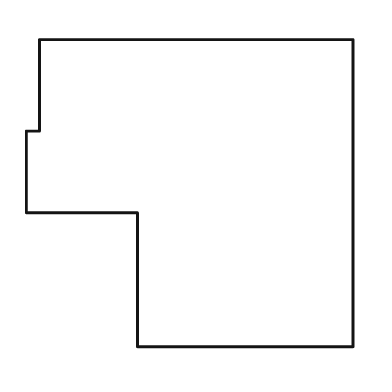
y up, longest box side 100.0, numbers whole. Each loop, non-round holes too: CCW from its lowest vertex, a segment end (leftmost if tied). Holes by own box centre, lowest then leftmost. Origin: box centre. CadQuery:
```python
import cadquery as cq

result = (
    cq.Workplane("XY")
    .moveTo(-16.0, -47.0)
    .lineTo(50.0, -47.0)
    .lineTo(50.0, 47.0)
    .lineTo(-46.0, 47.0)
    .lineTo(-46.0, 19.0)
    .lineTo(-50.0, 19.0)
    .lineTo(-50.0, -6.0)
    .lineTo(-16.0, -6.0)
    .close()
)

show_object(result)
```